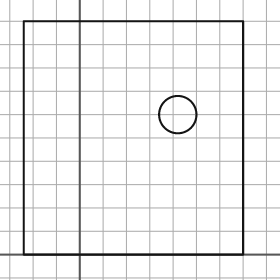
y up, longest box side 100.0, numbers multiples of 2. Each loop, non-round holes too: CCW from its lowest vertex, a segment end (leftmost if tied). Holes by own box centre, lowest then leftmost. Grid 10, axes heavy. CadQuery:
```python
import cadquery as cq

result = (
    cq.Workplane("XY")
    .moveTo(-24.0, 0.0)
    .lineTo(70.0, 0.0)
    .lineTo(70.0, 100.0)
    .lineTo(-24.0, 100.0)
    .close()
    .moveTo(42.0, 60.0)
    .circle(8.0)
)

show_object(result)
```